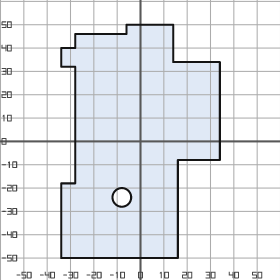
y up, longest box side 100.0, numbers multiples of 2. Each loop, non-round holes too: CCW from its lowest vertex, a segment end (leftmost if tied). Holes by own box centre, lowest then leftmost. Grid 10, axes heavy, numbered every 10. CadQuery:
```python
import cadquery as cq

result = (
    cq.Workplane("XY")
    .moveTo(-34.0, -50.0)
    .lineTo(16.0, -50.0)
    .lineTo(16.0, -8.0)
    .lineTo(34.0, -8.0)
    .lineTo(34.0, 34.0)
    .lineTo(14.0, 34.0)
    .lineTo(14.0, 50.0)
    .lineTo(-6.0, 50.0)
    .lineTo(-6.0, 46.0)
    .lineTo(-28.0, 46.0)
    .lineTo(-28.0, 40.0)
    .lineTo(-34.0, 40.0)
    .lineTo(-34.0, 32.0)
    .lineTo(-28.0, 32.0)
    .lineTo(-28.0, -18.0)
    .lineTo(-34.0, -18.0)
    .close()
    .moveTo(-8.0, -24.0)
    .circle(4.0)
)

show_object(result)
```